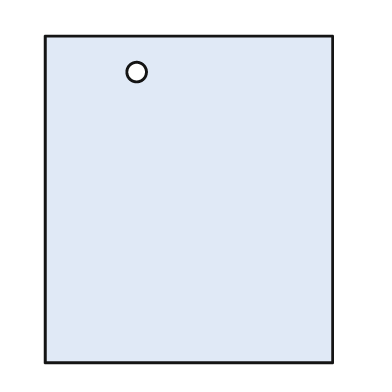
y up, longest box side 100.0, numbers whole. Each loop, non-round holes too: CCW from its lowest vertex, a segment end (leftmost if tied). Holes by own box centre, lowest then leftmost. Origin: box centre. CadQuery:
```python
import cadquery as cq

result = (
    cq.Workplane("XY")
    .moveTo(-44.0, -50.0)
    .lineTo(44.0, -50.0)
    .lineTo(44.0, 50.0)
    .lineTo(-44.0, 50.0)
    .close()
    .moveTo(-16.0, 39.0)
    .circle(3.0)
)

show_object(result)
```